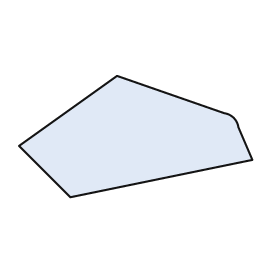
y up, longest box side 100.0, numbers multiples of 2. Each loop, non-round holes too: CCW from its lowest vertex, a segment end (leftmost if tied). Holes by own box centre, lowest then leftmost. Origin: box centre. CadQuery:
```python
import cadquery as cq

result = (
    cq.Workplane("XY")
    .moveTo(-28.0, -26.0)
    .lineTo(50.0, -10.0)
    .lineTo(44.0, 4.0)
    .threePointArc((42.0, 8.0), (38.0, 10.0))
    .lineTo(-8.0, 26.0)
    .lineTo(-50.0, -4.0)
    .close()
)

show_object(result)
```